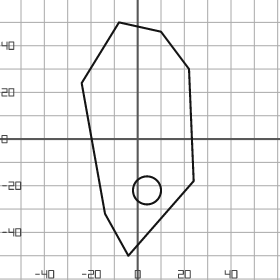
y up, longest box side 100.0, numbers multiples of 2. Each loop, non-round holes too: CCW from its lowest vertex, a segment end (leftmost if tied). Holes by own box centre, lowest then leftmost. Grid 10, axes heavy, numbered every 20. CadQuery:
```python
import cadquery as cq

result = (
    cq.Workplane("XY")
    .moveTo(-4.0, -50.0)
    .lineTo(24.0, -18.0)
    .lineTo(22.0, 30.0)
    .lineTo(10.0, 46.0)
    .lineTo(-8.0, 50.0)
    .lineTo(-24.0, 24.0)
    .lineTo(-14.0, -32.0)
    .close()
    .moveTo(4.0, -22.0)
    .circle(6.0)
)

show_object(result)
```